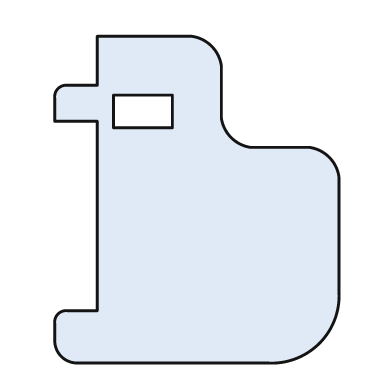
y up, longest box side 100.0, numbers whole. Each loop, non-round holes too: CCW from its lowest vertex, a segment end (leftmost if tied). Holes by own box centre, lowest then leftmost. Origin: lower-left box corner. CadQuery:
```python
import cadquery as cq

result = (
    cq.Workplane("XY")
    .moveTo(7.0, 0.0)
    .lineTo(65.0, 0.0)
    .threePointArc((81.0, 6.0), (87.0, 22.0))
    .lineTo(87.0, 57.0)
    .threePointArc((84.0, 63.0), (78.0, 66.0))
    .lineTo(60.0, 66.0)
    .threePointArc((54.0, 69.0), (51.0, 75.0))
    .lineTo(51.0, 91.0)
    .threePointArc((48.0, 97.0), (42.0, 100.0))
    .lineTo(13.0, 100.0)
    .lineTo(13.0, 85.0)
    .lineTo(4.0, 85.0)
    .threePointArc((1.0, 84.0), (0.0, 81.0))
    .lineTo(0.0, 74.0)
    .lineTo(13.0, 74.0)
    .lineTo(13.0, 16.0)
    .lineTo(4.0, 16.0)
    .threePointArc((1.0, 15.0), (0.0, 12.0))
    .lineTo(0.0, 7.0)
    .threePointArc((2.0, 2.0), (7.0, 0.0))
    .close()
    .moveTo(18.0, 72.0)
    .lineTo(36.0, 72.0)
    .lineTo(36.0, 82.0)
    .lineTo(18.0, 82.0)
    .close()
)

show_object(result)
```